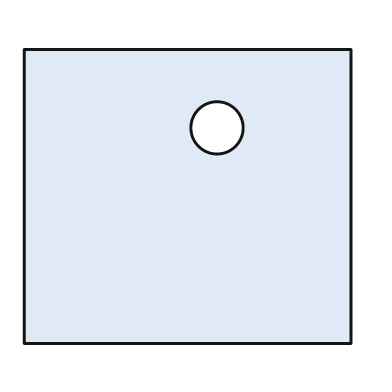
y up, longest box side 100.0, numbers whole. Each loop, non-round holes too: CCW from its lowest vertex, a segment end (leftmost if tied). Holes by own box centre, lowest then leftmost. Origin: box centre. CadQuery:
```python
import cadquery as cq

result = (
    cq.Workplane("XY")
    .moveTo(-50.0, -45.0)
    .lineTo(50.0, -45.0)
    .lineTo(50.0, 45.0)
    .lineTo(-50.0, 45.0)
    .close()
    .moveTo(9.0, 21.0)
    .circle(8.0)
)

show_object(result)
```